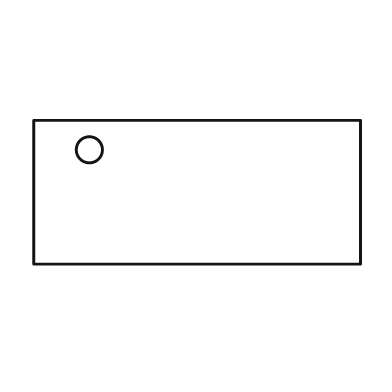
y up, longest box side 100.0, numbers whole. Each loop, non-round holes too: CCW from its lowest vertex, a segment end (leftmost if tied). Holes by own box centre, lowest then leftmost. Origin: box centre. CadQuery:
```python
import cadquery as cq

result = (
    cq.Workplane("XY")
    .moveTo(-50.0, -22.0)
    .lineTo(50.0, -22.0)
    .lineTo(50.0, 22.0)
    .lineTo(-50.0, 22.0)
    .close()
    .moveTo(-33.0, 13.0)
    .circle(4.0)
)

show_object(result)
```